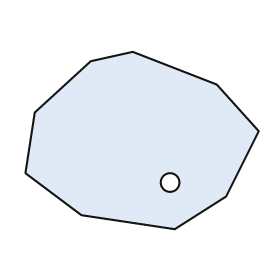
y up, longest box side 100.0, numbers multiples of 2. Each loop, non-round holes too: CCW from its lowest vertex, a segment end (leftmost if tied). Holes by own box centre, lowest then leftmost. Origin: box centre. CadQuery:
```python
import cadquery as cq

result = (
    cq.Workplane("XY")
    .moveTo(14.0, -38.0)
    .lineTo(36.0, -24.0)
    .lineTo(50.0, 4.0)
    .lineTo(32.0, 24.0)
    .lineTo(-4.0, 38.0)
    .lineTo(-22.0, 34.0)
    .lineTo(-46.0, 12.0)
    .lineTo(-50.0, -14.0)
    .lineTo(-26.0, -32.0)
    .close()
    .moveTo(12.0, -18.0)
    .circle(4.0)
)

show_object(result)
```